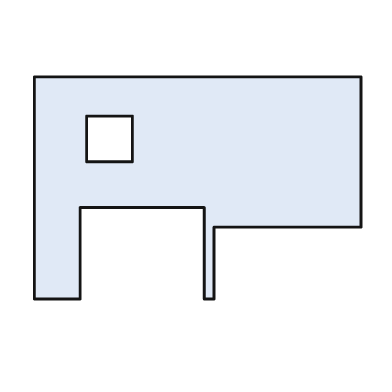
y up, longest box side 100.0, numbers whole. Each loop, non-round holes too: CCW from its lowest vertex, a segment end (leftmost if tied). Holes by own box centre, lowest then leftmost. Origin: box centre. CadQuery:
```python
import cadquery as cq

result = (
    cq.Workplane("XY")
    .moveTo(-50.0, -34.0)
    .lineTo(-36.0, -34.0)
    .lineTo(-36.0, -6.0)
    .lineTo(2.0, -6.0)
    .lineTo(2.0, -34.0)
    .lineTo(5.0, -34.0)
    .lineTo(5.0, -12.0)
    .lineTo(50.0, -12.0)
    .lineTo(50.0, 34.0)
    .lineTo(-50.0, 34.0)
    .close()
    .moveTo(-34.0, 8.0)
    .lineTo(-20.0, 8.0)
    .lineTo(-20.0, 22.0)
    .lineTo(-34.0, 22.0)
    .close()
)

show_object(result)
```